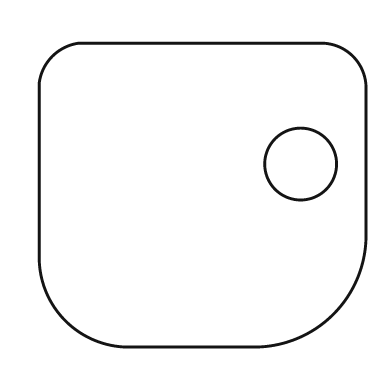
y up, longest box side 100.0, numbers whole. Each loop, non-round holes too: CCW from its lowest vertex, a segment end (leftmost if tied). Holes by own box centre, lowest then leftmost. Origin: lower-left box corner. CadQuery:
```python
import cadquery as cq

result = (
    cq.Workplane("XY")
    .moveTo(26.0, 0.0)
    .lineTo(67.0, 0.0)
    .threePointArc((90.0, 10.0), (100.0, 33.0))
    .lineTo(100.0, 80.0)
    .threePointArc((96.0, 89.0), (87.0, 93.0))
    .lineTo(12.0, 93.0)
    .threePointArc((4.0, 89.0), (0.0, 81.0))
    .lineTo(0.0, 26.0)
    .threePointArc((8.0, 8.0), (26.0, 0.0))
    .close()
    .moveTo(80.0, 56.0)
    .circle(11.0)
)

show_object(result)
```